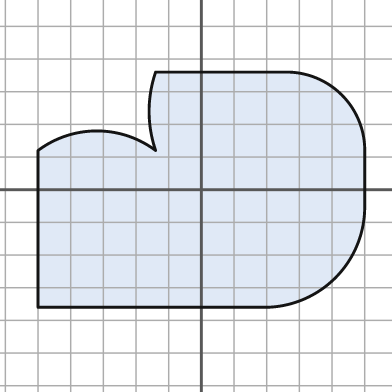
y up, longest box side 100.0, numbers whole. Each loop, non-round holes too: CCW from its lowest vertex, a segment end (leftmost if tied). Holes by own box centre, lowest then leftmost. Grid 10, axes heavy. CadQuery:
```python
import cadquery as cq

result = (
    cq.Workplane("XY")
    .moveTo(-50.0, -36.0)
    .lineTo(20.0, -36.0)
    .threePointArc((41.0, -27.0), (50.0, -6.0))
    .lineTo(50.0, 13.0)
    .threePointArc((43.0, 29.0), (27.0, 36.0))
    .lineTo(-14.0, 36.0)
    .threePointArc((-16.0, 24.0), (-14.0, 12.0))
    .threePointArc((-32.0, 18.0), (-50.0, 12.0))
    .close()
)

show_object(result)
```